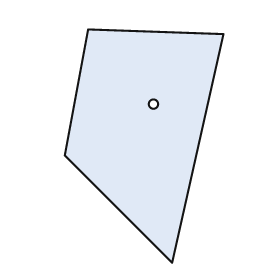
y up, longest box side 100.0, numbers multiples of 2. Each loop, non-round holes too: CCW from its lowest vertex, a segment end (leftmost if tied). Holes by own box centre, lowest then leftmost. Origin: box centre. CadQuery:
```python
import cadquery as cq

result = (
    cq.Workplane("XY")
    .moveTo(12.0, -50.0)
    .lineTo(34.0, 48.0)
    .lineTo(-24.0, 50.0)
    .lineTo(-34.0, -4.0)
    .close()
    .moveTo(4.0, 18.0)
    .circle(2.0)
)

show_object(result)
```